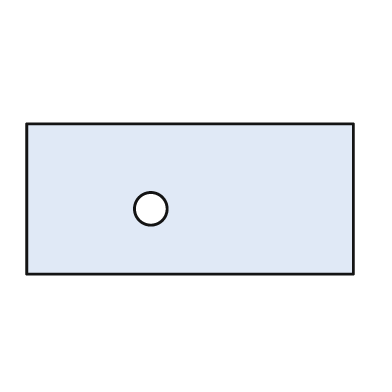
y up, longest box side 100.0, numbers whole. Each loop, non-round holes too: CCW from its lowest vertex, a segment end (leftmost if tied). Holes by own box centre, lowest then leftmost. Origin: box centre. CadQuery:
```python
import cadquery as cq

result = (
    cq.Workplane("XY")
    .moveTo(-50.0, -23.0)
    .lineTo(50.0, -23.0)
    .lineTo(50.0, 23.0)
    .lineTo(-50.0, 23.0)
    .close()
    .moveTo(-12.0, -3.0)
    .circle(5.0)
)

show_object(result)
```